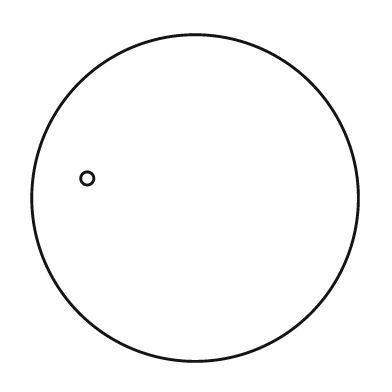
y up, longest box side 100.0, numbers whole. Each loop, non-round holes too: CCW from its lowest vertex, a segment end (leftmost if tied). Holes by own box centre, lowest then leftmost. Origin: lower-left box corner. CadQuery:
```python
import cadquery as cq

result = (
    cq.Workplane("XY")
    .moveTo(50.0, 50.0)
    .circle(50.0)
    .moveTo(17.0, 56.0)
    .circle(2.0)
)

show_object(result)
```